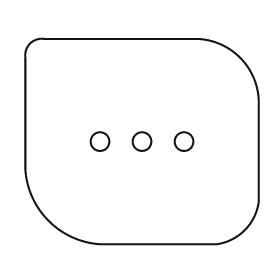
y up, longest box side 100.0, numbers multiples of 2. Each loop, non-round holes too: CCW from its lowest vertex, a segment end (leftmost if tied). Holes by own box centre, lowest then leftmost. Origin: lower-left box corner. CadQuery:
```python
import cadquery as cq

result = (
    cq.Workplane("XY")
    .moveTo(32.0, 0.0)
    .lineTo(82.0, 0.0)
    .threePointArc((94.0, 6.0), (100.0, 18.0))
    .lineTo(100.0, 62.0)
    .threePointArc((92.0, 80.0), (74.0, 88.0))
    .lineTo(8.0, 88.0)
    .threePointArc((2.0, 86.0), (0.0, 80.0))
    .lineTo(0.0, 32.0)
    .threePointArc((10.0, 10.0), (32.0, 0.0))
    .close()
    .moveTo(32.0, 44.0)
    .circle(4.0)
    .moveTo(50.0, 44.0)
    .circle(4.0)
    .moveTo(68.0, 44.0)
    .circle(4.0)
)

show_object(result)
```